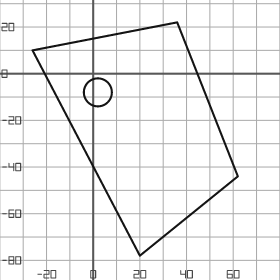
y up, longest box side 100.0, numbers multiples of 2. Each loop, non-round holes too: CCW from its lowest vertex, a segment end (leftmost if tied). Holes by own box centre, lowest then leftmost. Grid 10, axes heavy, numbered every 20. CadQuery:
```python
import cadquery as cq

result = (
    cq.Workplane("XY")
    .moveTo(20.0, -78.0)
    .lineTo(62.0, -44.0)
    .lineTo(36.0, 22.0)
    .lineTo(-26.0, 10.0)
    .close()
    .moveTo(2.0, -8.0)
    .circle(6.0)
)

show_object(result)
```